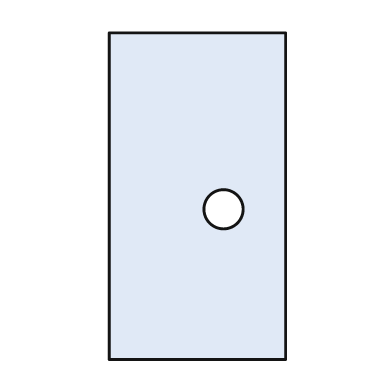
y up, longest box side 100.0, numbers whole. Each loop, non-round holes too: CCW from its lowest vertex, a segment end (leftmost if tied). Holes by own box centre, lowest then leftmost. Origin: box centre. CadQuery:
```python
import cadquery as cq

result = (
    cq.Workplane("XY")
    .moveTo(-27.0, -50.0)
    .lineTo(27.0, -50.0)
    .lineTo(27.0, 50.0)
    .lineTo(-27.0, 50.0)
    .close()
    .moveTo(8.0, -4.0)
    .circle(6.0)
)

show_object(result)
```